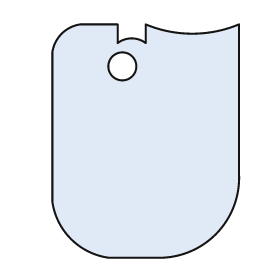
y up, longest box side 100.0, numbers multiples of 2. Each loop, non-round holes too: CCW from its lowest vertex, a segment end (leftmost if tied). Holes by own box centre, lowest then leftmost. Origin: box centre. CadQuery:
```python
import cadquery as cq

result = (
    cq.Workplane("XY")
    .moveTo(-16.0, -50.0)
    .lineTo(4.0, -50.0)
    .threePointArc((30.0, -40.0), (40.0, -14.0))
    .lineTo(40.0, 50.0)
    .threePointArc((20.0, 46.0), (0.0, 50.0))
    .lineTo(0.0, 42.0)
    .threePointArc((-6.0, 44.0), (-12.0, 42.0))
    .lineTo(-12.0, 50.0)
    .lineTo(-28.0, 50.0)
    .threePointArc((-36.0, 46.0), (-40.0, 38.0))
    .lineTo(-40.0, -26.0)
    .threePointArc((-32.0, -42.0), (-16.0, -50.0))
    .close()
    .moveTo(-10.0, 32.0)
    .circle(6.0)
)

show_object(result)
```